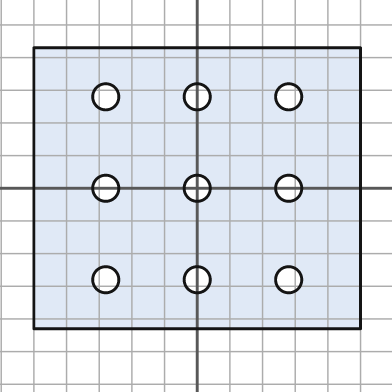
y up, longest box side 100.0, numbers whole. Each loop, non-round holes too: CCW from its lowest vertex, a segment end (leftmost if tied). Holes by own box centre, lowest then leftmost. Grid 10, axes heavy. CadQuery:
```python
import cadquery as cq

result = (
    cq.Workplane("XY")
    .moveTo(-50.0, -43.0)
    .lineTo(50.0, -43.0)
    .lineTo(50.0, 43.0)
    .lineTo(-50.0, 43.0)
    .close()
    .moveTo(-28.0, -28.0)
    .circle(4.0)
    .moveTo(0.0, -28.0)
    .circle(4.0)
    .moveTo(28.0, -28.0)
    .circle(4.0)
    .moveTo(-28.0, 0.0)
    .circle(4.0)
    .moveTo(0.0, 0.0)
    .circle(4.0)
    .moveTo(28.0, 0.0)
    .circle(4.0)
    .moveTo(-28.0, 28.0)
    .circle(4.0)
    .moveTo(0.0, 28.0)
    .circle(4.0)
    .moveTo(28.0, 28.0)
    .circle(4.0)
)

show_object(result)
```